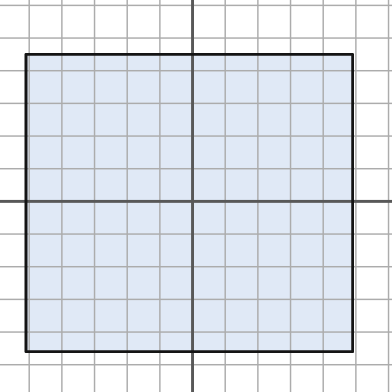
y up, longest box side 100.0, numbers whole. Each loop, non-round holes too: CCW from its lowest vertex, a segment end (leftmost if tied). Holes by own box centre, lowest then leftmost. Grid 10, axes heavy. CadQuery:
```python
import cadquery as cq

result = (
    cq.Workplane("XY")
    .moveTo(-51.0, -46.0)
    .lineTo(49.0, -46.0)
    .lineTo(49.0, 45.0)
    .lineTo(-51.0, 45.0)
    .close()
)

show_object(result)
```